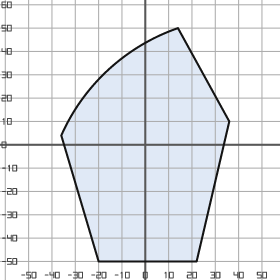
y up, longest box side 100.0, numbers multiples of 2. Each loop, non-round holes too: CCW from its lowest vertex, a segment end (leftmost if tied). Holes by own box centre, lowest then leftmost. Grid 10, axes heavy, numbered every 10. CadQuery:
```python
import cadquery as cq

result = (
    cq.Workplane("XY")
    .moveTo(-20.0, -50.0)
    .lineTo(22.0, -50.0)
    .lineTo(36.0, 10.0)
    .lineTo(14.0, 50.0)
    .threePointArc((-16.0, 32.0), (-36.0, 4.0))
    .close()
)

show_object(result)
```